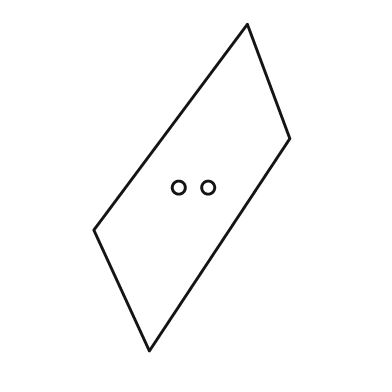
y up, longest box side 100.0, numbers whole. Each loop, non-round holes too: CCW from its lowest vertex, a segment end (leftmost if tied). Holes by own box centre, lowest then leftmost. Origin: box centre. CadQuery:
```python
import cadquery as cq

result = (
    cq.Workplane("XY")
    .moveTo(-13.0, -50.0)
    .lineTo(30.0, 15.0)
    .lineTo(17.0, 50.0)
    .lineTo(-30.0, -13.0)
    .close()
    .moveTo(-4.0, 0.0)
    .circle(2.0)
    .moveTo(5.0, 0.0)
    .circle(2.0)
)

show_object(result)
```